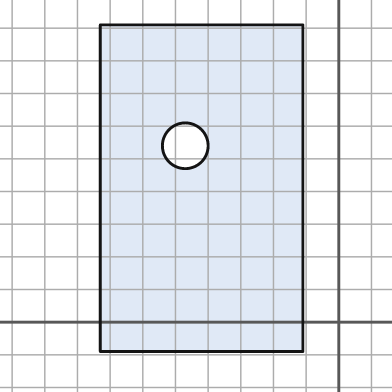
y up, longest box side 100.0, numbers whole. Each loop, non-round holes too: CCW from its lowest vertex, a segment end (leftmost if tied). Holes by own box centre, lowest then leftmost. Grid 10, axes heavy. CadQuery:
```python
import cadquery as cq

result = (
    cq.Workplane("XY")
    .moveTo(-73.0, -9.0)
    .lineTo(-11.0, -9.0)
    .lineTo(-11.0, 91.0)
    .lineTo(-73.0, 91.0)
    .close()
    .moveTo(-47.0, 54.0)
    .circle(7.0)
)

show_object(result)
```